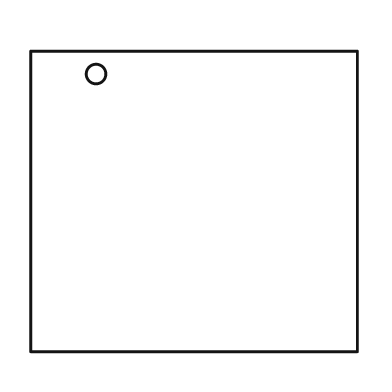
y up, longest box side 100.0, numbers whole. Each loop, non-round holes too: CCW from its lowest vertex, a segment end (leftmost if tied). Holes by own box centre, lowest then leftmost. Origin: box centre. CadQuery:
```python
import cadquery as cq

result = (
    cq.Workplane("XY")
    .moveTo(-50.0, -46.0)
    .lineTo(50.0, -46.0)
    .lineTo(50.0, 46.0)
    .lineTo(-50.0, 46.0)
    .close()
    .moveTo(-30.0, 39.0)
    .circle(3.0)
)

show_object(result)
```